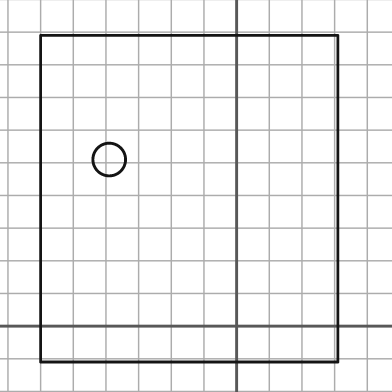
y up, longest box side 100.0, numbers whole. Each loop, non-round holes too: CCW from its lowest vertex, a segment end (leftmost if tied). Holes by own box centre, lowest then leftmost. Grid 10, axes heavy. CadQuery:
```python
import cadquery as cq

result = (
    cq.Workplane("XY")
    .moveTo(-60.0, -11.0)
    .lineTo(31.0, -11.0)
    .lineTo(31.0, 89.0)
    .lineTo(-60.0, 89.0)
    .close()
    .moveTo(-39.0, 51.0)
    .circle(5.0)
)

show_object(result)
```